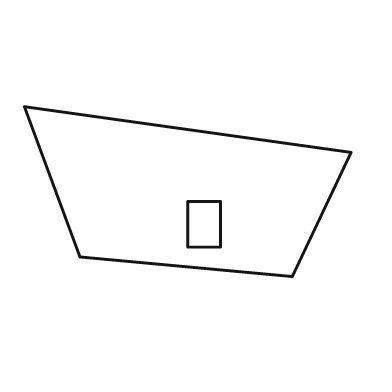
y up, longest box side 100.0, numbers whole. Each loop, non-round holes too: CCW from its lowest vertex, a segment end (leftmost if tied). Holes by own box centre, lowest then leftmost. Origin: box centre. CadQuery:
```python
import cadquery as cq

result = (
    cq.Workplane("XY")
    .moveTo(32.0, -26.0)
    .lineTo(50.0, 12.0)
    .lineTo(-50.0, 26.0)
    .lineTo(-33.0, -20.0)
    .close()
    .moveTo(0.0, -17.0)
    .lineTo(10.0, -17.0)
    .lineTo(10.0, -3.0)
    .lineTo(0.0, -3.0)
    .close()
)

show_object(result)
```